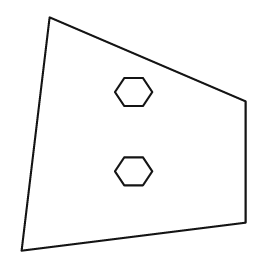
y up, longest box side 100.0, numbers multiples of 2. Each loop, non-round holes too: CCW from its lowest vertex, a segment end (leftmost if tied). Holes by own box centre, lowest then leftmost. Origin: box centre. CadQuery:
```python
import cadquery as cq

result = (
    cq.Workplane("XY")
    .moveTo(-48.0, -50.0)
    .lineTo(48.0, -38.0)
    .lineTo(48.0, 14.0)
    .lineTo(-36.0, 50.0)
    .close()
    .moveTo(-4.0, -22.0)
    .lineTo(4.0, -22.0)
    .lineTo(8.0, -16.0)
    .lineTo(4.0, -10.0)
    .lineTo(-4.0, -10.0)
    .lineTo(-8.0, -16.0)
    .close()
    .moveTo(-4.0, 12.0)
    .lineTo(4.0, 12.0)
    .lineTo(8.0, 18.0)
    .lineTo(4.0, 24.0)
    .lineTo(-4.0, 24.0)
    .lineTo(-8.0, 18.0)
    .close()
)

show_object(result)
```